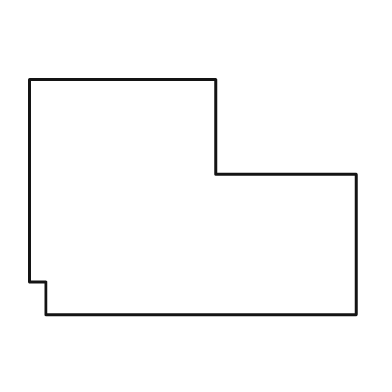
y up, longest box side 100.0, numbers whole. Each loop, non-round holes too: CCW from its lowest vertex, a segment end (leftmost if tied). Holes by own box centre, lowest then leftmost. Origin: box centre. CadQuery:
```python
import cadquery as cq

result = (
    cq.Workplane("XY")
    .moveTo(-45.0, -36.0)
    .lineTo(50.0, -36.0)
    .lineTo(50.0, 7.0)
    .lineTo(7.0, 7.0)
    .lineTo(7.0, 36.0)
    .lineTo(-50.0, 36.0)
    .lineTo(-50.0, -26.0)
    .lineTo(-45.0, -26.0)
    .close()
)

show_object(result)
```